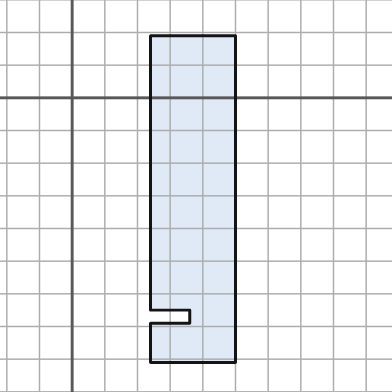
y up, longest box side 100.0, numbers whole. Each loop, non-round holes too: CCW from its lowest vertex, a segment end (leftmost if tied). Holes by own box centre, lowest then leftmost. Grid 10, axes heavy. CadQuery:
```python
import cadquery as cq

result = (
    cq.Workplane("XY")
    .moveTo(24.0, -81.0)
    .lineTo(50.0, -81.0)
    .lineTo(50.0, 19.0)
    .lineTo(24.0, 19.0)
    .lineTo(24.0, -65.0)
    .lineTo(36.0, -65.0)
    .lineTo(36.0, -69.0)
    .lineTo(24.0, -69.0)
    .close()
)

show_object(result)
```